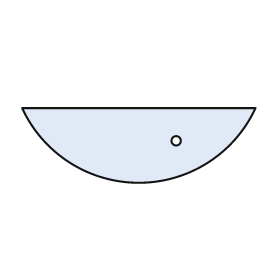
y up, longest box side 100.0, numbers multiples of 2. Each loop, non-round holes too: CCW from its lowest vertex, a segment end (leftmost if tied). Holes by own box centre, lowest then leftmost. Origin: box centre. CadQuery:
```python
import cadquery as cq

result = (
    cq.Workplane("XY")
    .moveTo(-50.0, 16.0)
    .threePointArc((0.0, -16.0), (50.0, 16.0))
    .close()
    .moveTo(16.0, 2.0)
    .circle(2.0)
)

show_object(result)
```